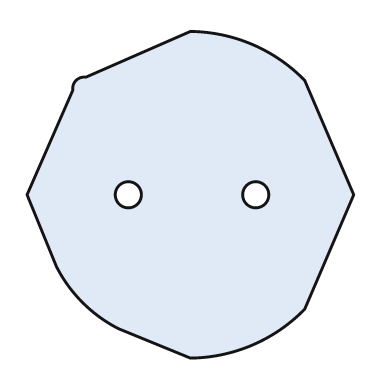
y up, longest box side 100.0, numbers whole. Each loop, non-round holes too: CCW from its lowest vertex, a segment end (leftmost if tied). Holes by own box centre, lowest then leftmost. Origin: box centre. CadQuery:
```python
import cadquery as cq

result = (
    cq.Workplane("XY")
    .moveTo(0.0, -50.0)
    .threePointArc((19.0, -46.0), (35.0, -35.0))
    .lineTo(50.0, 0.0)
    .lineTo(35.0, 35.0)
    .threePointArc((19.0, 46.0), (0.0, 50.0))
    .lineTo(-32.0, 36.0)
    .threePointArc((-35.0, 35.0), (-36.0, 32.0))
    .lineTo(-50.0, 0.0)
    .lineTo(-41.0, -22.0)
    .threePointArc((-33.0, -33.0), (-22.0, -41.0))
    .close()
    .moveTo(-19.0, 0.0)
    .circle(4.0)
    .moveTo(20.0, 0.0)
    .circle(4.0)
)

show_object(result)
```